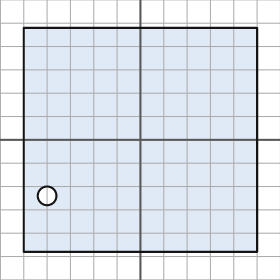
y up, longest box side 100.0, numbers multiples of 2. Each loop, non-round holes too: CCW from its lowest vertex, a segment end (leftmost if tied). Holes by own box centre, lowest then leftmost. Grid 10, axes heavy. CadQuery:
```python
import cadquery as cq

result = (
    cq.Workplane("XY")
    .moveTo(-50.0, -48.0)
    .lineTo(50.0, -48.0)
    .lineTo(50.0, 48.0)
    .lineTo(-50.0, 48.0)
    .close()
    .moveTo(-40.0, -24.0)
    .circle(4.0)
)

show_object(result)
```